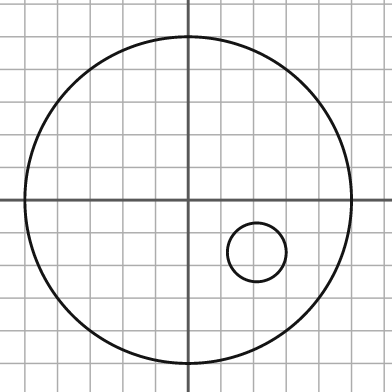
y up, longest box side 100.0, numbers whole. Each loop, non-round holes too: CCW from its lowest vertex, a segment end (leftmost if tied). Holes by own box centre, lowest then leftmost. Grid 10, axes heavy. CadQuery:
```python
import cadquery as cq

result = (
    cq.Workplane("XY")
    .moveTo(0.0, 0.0)
    .circle(50.0)
    .moveTo(21.0, -16.0)
    .circle(9.0)
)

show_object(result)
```